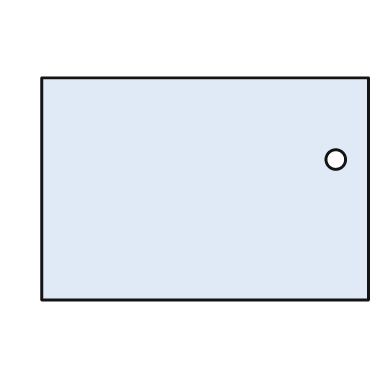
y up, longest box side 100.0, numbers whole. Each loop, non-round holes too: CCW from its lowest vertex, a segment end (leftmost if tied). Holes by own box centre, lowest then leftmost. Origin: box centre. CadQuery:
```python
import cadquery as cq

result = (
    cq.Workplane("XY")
    .moveTo(-50.0, -34.0)
    .lineTo(50.0, -34.0)
    .lineTo(50.0, 34.0)
    .lineTo(-50.0, 34.0)
    .close()
    .moveTo(40.0, 9.0)
    .circle(3.0)
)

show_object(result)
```